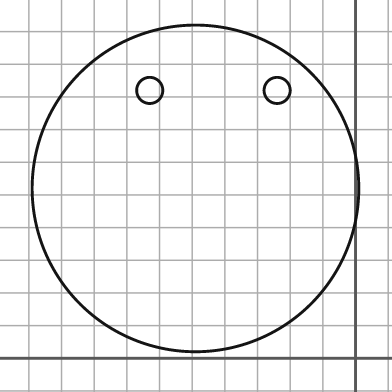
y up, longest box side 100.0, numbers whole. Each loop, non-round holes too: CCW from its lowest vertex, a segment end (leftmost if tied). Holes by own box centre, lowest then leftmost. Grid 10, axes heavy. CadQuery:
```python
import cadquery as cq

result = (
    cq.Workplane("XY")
    .moveTo(-49.0, 52.0)
    .circle(50.0)
    .moveTo(-63.0, 82.0)
    .circle(4.0)
    .moveTo(-24.0, 82.0)
    .circle(4.0)
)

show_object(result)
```